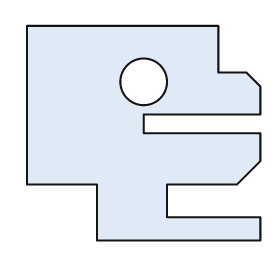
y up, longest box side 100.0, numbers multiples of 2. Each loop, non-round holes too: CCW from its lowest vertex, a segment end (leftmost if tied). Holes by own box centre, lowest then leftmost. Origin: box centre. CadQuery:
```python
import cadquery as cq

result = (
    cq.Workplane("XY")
    .moveTo(-20.0, -46.0)
    .lineTo(50.0, -46.0)
    .lineTo(50.0, -36.0)
    .lineTo(10.0, -36.0)
    .lineTo(10.0, -22.0)
    .lineTo(40.0, -22.0)
    .lineTo(50.0, -12.0)
    .lineTo(50.0, 0.0)
    .lineTo(0.0, 0.0)
    .lineTo(0.0, 8.0)
    .lineTo(50.0, 8.0)
    .lineTo(50.0, 20.0)
    .lineTo(44.0, 26.0)
    .lineTo(32.0, 26.0)
    .lineTo(32.0, 46.0)
    .lineTo(-50.0, 46.0)
    .lineTo(-50.0, -22.0)
    .lineTo(-20.0, -22.0)
    .close()
    .moveTo(0.0, 22.0)
    .circle(10.0)
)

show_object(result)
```